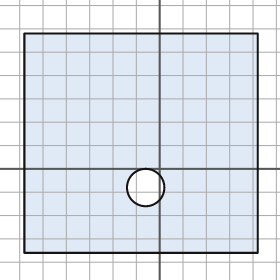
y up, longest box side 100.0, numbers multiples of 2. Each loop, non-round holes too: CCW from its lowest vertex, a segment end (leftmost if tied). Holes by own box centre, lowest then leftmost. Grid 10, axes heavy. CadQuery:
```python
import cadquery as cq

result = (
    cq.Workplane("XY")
    .moveTo(-58.0, -36.0)
    .lineTo(42.0, -36.0)
    .lineTo(42.0, 58.0)
    .lineTo(-58.0, 58.0)
    .close()
    .moveTo(-6.0, -8.0)
    .circle(8.0)
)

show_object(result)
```